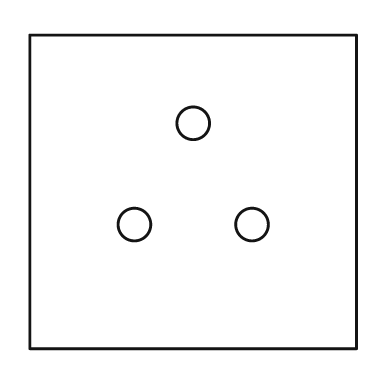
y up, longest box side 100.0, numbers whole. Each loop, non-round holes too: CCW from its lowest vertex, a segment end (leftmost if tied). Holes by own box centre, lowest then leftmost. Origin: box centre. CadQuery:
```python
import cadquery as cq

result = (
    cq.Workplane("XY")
    .moveTo(-50.0, -48.0)
    .lineTo(50.0, -48.0)
    .lineTo(50.0, 48.0)
    .lineTo(-50.0, 48.0)
    .close()
    .moveTo(-18.0, -10.0)
    .circle(5.0)
    .moveTo(18.0, -10.0)
    .circle(5.0)
    .moveTo(0.0, 21.0)
    .circle(5.0)
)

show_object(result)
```